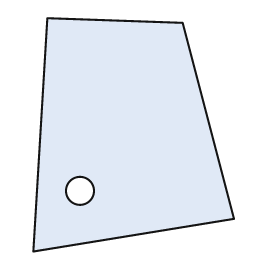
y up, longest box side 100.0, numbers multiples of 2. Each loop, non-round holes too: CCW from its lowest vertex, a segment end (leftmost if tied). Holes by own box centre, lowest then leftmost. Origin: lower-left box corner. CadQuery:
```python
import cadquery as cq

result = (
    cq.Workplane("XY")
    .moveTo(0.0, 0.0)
    .lineTo(86.0, 14.0)
    .lineTo(64.0, 98.0)
    .lineTo(6.0, 100.0)
    .close()
    .moveTo(20.0, 26.0)
    .circle(6.0)
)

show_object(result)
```